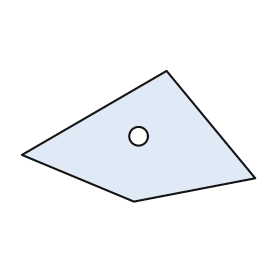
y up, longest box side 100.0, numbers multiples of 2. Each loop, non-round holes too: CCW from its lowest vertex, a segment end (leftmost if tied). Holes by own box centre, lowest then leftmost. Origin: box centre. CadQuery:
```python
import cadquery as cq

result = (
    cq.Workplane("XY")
    .moveTo(-2.0, -28.0)
    .lineTo(50.0, -18.0)
    .lineTo(12.0, 28.0)
    .lineTo(-50.0, -8.0)
    .close()
    .moveTo(0.0, 0.0)
    .circle(4.0)
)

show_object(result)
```